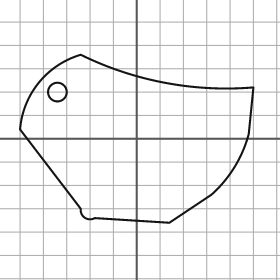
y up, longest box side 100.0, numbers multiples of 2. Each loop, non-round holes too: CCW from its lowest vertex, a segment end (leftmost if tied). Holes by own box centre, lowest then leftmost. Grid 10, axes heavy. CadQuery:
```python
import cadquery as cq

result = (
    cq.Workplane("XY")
    .moveTo(14.0, -36.0)
    .lineTo(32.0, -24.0)
    .threePointArc((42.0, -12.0), (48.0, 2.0))
    .lineTo(50.0, 22.0)
    .threePointArc((12.0, 24.0), (-24.0, 36.0))
    .threePointArc((-42.0, 24.0), (-50.0, 4.0))
    .lineTo(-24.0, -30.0)
    .threePointArc((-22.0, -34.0), (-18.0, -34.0))
    .close()
    .moveTo(-34.0, 20.0)
    .circle(4.0)
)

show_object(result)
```